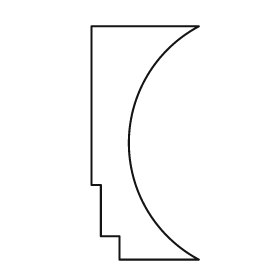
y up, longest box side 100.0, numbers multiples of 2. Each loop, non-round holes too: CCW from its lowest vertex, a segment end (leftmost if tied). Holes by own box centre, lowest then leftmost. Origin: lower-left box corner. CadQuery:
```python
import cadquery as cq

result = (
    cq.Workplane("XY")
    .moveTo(12.0, 0.0)
    .lineTo(46.0, 0.0)
    .threePointArc((16.0, 50.0), (46.0, 100.0))
    .lineTo(0.0, 100.0)
    .lineTo(0.0, 32.0)
    .lineTo(4.0, 32.0)
    .lineTo(4.0, 10.0)
    .lineTo(12.0, 10.0)
    .close()
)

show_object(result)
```